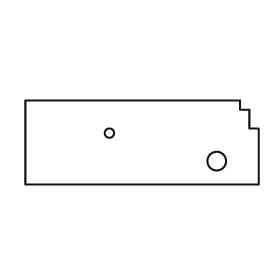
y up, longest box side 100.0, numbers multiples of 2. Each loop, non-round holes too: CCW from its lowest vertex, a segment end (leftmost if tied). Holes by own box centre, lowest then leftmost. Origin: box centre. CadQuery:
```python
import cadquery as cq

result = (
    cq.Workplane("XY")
    .moveTo(-50.0, -18.0)
    .lineTo(50.0, -18.0)
    .lineTo(50.0, 6.0)
    .lineTo(46.0, 6.0)
    .lineTo(46.0, 14.0)
    .lineTo(42.0, 14.0)
    .lineTo(42.0, 18.0)
    .lineTo(-50.0, 18.0)
    .close()
    .moveTo(32.0, -8.0)
    .circle(4.0)
    .moveTo(-14.0, 4.0)
    .circle(2.0)
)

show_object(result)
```